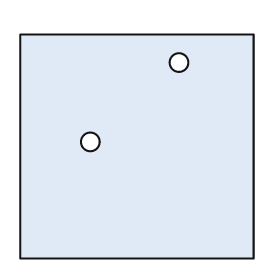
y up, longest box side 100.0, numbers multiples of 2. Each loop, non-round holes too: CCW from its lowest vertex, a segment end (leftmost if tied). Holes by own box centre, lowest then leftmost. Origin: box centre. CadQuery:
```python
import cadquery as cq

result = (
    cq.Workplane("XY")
    .moveTo(-50.0, -48.0)
    .lineTo(50.0, -48.0)
    .lineTo(50.0, 48.0)
    .lineTo(-50.0, 48.0)
    .close()
    .moveTo(-20.0, 2.0)
    .circle(4.0)
    .moveTo(18.0, 36.0)
    .circle(4.0)
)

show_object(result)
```